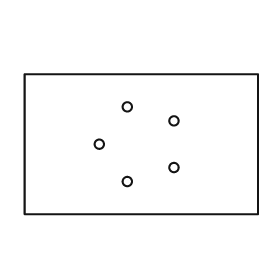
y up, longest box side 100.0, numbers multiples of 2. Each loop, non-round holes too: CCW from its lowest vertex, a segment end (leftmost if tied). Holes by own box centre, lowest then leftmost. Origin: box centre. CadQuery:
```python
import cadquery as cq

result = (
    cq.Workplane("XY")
    .moveTo(-50.0, -30.0)
    .lineTo(50.0, -30.0)
    .lineTo(50.0, 30.0)
    .lineTo(-50.0, 30.0)
    .close()
    .moveTo(-6.0, -16.0)
    .circle(2.0)
    .moveTo(14.0, -10.0)
    .circle(2.0)
    .moveTo(-18.0, 0.0)
    .circle(2.0)
    .moveTo(14.0, 10.0)
    .circle(2.0)
    .moveTo(-6.0, 16.0)
    .circle(2.0)
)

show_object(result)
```